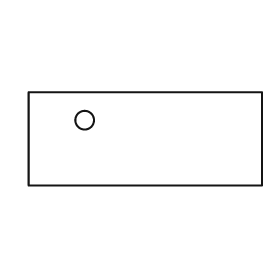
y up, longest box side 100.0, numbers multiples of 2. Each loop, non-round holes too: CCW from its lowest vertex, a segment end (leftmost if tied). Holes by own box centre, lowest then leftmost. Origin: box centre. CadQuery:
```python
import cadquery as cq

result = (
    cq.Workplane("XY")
    .moveTo(-50.0, -20.0)
    .lineTo(50.0, -20.0)
    .lineTo(50.0, 20.0)
    .lineTo(-50.0, 20.0)
    .close()
    .moveTo(-26.0, 8.0)
    .circle(4.0)
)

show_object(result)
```